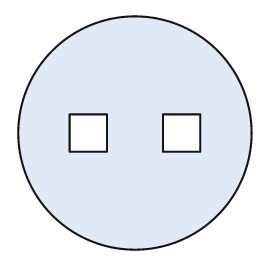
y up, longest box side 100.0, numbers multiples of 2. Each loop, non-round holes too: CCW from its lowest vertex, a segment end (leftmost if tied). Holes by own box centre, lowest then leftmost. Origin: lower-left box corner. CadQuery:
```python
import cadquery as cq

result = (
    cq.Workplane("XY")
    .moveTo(50.0, 50.0)
    .circle(50.0)
    .moveTo(22.0, 42.0)
    .lineTo(38.0, 42.0)
    .lineTo(38.0, 58.0)
    .lineTo(22.0, 58.0)
    .close()
    .moveTo(62.0, 42.0)
    .lineTo(78.0, 42.0)
    .lineTo(78.0, 58.0)
    .lineTo(62.0, 58.0)
    .close()
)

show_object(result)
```